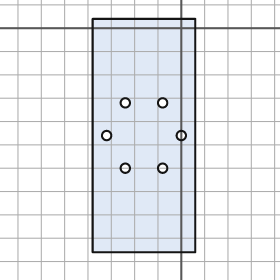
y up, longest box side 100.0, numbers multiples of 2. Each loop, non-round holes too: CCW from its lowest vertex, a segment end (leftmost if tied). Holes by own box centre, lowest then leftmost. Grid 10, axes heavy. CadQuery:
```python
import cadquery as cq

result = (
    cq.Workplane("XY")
    .moveTo(-38.0, -96.0)
    .lineTo(6.0, -96.0)
    .lineTo(6.0, 4.0)
    .lineTo(-38.0, 4.0)
    .close()
    .moveTo(-24.0, -60.0)
    .circle(2.0)
    .moveTo(-8.0, -60.0)
    .circle(2.0)
    .moveTo(-32.0, -46.0)
    .circle(2.0)
    .moveTo(0.0, -46.0)
    .circle(2.0)
    .moveTo(-24.0, -32.0)
    .circle(2.0)
    .moveTo(-8.0, -32.0)
    .circle(2.0)
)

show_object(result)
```